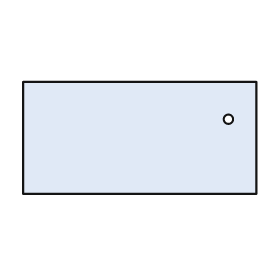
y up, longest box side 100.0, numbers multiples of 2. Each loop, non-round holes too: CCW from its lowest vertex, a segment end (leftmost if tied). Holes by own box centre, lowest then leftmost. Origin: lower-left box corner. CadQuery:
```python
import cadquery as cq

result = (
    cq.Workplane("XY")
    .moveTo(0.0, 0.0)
    .lineTo(100.0, 0.0)
    .lineTo(100.0, 48.0)
    .lineTo(0.0, 48.0)
    .close()
    .moveTo(88.0, 32.0)
    .circle(2.0)
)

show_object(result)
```